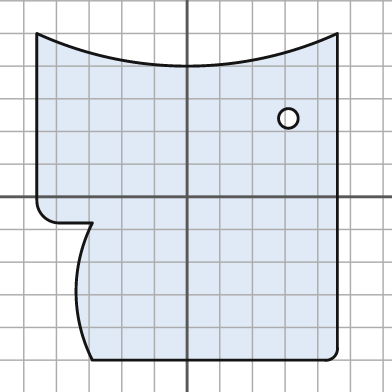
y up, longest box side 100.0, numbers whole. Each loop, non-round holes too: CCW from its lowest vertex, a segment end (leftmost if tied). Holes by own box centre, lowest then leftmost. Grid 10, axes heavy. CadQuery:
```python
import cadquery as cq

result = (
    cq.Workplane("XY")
    .moveTo(-29.0, -50.0)
    .lineTo(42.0, -50.0)
    .threePointArc((45.0, -49.0), (46.0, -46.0))
    .lineTo(46.0, 50.0)
    .threePointArc((0.0, 40.0), (-46.0, 50.0))
    .lineTo(-46.0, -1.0)
    .threePointArc((-44.0, -6.0), (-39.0, -8.0))
    .lineTo(-29.0, -8.0)
    .threePointArc((-34.0, -29.0), (-29.0, -50.0))
    .close()
    .moveTo(31.0, 24.0)
    .circle(3.0)
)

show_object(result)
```